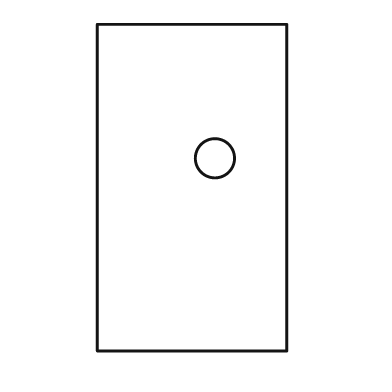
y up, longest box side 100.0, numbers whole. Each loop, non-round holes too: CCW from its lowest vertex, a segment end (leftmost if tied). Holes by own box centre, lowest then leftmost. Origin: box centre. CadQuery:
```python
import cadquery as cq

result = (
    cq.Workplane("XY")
    .moveTo(-29.0, -50.0)
    .lineTo(29.0, -50.0)
    .lineTo(29.0, 50.0)
    .lineTo(-29.0, 50.0)
    .close()
    .moveTo(7.0, 9.0)
    .circle(6.0)
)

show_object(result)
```